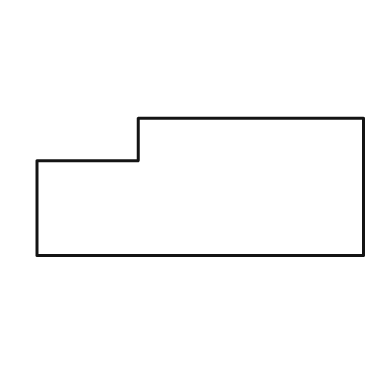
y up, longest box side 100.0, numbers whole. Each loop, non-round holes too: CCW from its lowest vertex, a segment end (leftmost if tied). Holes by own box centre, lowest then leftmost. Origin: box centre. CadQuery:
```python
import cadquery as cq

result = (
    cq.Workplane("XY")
    .moveTo(-50.0, -21.0)
    .lineTo(50.0, -21.0)
    .lineTo(50.0, 21.0)
    .lineTo(-19.0, 21.0)
    .lineTo(-19.0, 8.0)
    .lineTo(-50.0, 8.0)
    .close()
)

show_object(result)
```